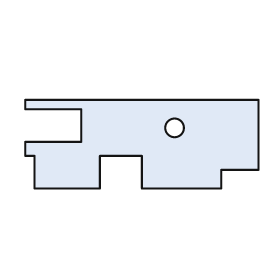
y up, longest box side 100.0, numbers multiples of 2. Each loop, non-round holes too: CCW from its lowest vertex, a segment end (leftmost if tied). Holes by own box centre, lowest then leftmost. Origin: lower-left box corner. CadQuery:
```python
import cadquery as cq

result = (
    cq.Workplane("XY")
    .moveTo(4.0, 0.0)
    .lineTo(32.0, 0.0)
    .lineTo(32.0, 14.0)
    .lineTo(50.0, 14.0)
    .lineTo(50.0, 0.0)
    .lineTo(84.0, 0.0)
    .lineTo(84.0, 8.0)
    .lineTo(100.0, 8.0)
    .lineTo(100.0, 38.0)
    .lineTo(0.0, 38.0)
    .lineTo(0.0, 34.0)
    .lineTo(24.0, 34.0)
    .lineTo(24.0, 20.0)
    .lineTo(0.0, 20.0)
    .lineTo(0.0, 14.0)
    .lineTo(4.0, 14.0)
    .close()
    .moveTo(64.0, 26.0)
    .circle(4.0)
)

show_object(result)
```